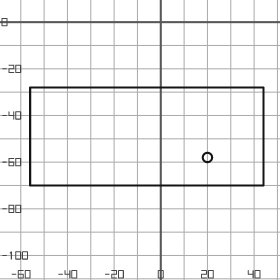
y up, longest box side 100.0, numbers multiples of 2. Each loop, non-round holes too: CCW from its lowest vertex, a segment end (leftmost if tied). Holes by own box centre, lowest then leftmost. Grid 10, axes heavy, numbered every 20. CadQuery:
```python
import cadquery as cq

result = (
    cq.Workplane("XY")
    .moveTo(-56.0, -70.0)
    .lineTo(44.0, -70.0)
    .lineTo(44.0, -28.0)
    .lineTo(-56.0, -28.0)
    .close()
    .moveTo(20.0, -58.0)
    .circle(2.0)
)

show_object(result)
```